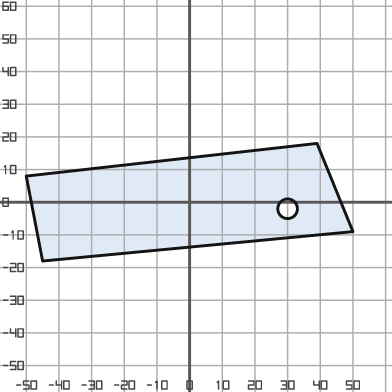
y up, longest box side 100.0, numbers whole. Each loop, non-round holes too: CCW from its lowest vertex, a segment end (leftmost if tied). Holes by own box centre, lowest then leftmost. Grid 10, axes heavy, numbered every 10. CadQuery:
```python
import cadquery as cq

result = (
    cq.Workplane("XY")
    .moveTo(-45.0, -18.0)
    .lineTo(50.0, -9.0)
    .lineTo(39.0, 18.0)
    .lineTo(-50.0, 8.0)
    .close()
    .moveTo(30.0, -2.0)
    .circle(3.0)
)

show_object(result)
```